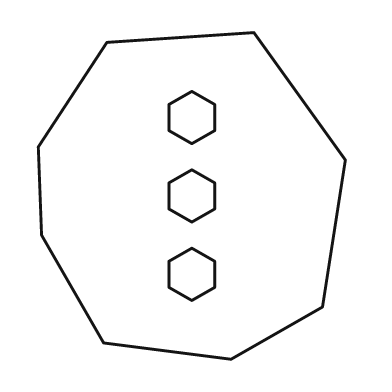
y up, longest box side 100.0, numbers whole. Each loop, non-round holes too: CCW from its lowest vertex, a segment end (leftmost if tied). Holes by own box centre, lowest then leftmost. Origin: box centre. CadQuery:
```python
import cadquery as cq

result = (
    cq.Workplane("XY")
    .moveTo(12.0, -50.0)
    .lineTo(40.0, -34.0)
    .lineTo(47.0, 11.0)
    .lineTo(19.0, 50.0)
    .lineTo(-26.0, 47.0)
    .lineTo(-47.0, 15.0)
    .lineTo(-46.0, -12.0)
    .lineTo(-27.0, -45.0)
    .close()
    .moveTo(0.0, -32.0)
    .lineTo(7.0, -28.0)
    .lineTo(7.0, -20.0)
    .lineTo(0.0, -16.0)
    .lineTo(-7.0, -20.0)
    .lineTo(-7.0, -28.0)
    .close()
    .moveTo(0.0, -8.0)
    .lineTo(7.0, -4.0)
    .lineTo(7.0, 4.0)
    .lineTo(0.0, 8.0)
    .lineTo(-7.0, 4.0)
    .lineTo(-7.0, -4.0)
    .close()
    .moveTo(0.0, 16.0)
    .lineTo(7.0, 20.0)
    .lineTo(7.0, 28.0)
    .lineTo(0.0, 32.0)
    .lineTo(-7.0, 28.0)
    .lineTo(-7.0, 20.0)
    .close()
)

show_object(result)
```